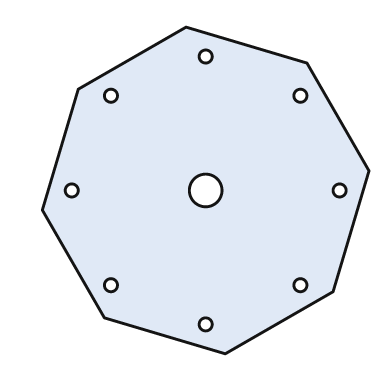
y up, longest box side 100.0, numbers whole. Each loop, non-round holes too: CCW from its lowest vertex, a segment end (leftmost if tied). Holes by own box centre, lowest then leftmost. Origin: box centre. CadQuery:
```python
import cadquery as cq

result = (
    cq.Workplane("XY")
    .moveTo(6.0, -50.0)
    .lineTo(39.0, -31.0)
    .lineTo(50.0, 6.0)
    .lineTo(31.0, 39.0)
    .lineTo(-6.0, 50.0)
    .lineTo(-39.0, 31.0)
    .lineTo(-50.0, -6.0)
    .lineTo(-31.0, -39.0)
    .close()
    .moveTo(0.0, -41.0)
    .circle(2.0)
    .moveTo(-29.0, -29.0)
    .circle(2.0)
    .moveTo(29.0, -29.0)
    .circle(2.0)
    .moveTo(-41.0, 0.0)
    .circle(2.0)
    .moveTo(0.0, 0.0)
    .circle(5.0)
    .moveTo(41.0, 0.0)
    .circle(2.0)
    .moveTo(-29.0, 29.0)
    .circle(2.0)
    .moveTo(29.0, 29.0)
    .circle(2.0)
    .moveTo(0.0, 41.0)
    .circle(2.0)
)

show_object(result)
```